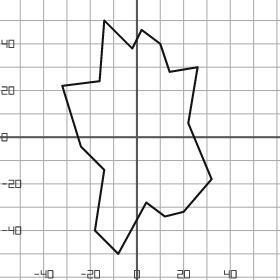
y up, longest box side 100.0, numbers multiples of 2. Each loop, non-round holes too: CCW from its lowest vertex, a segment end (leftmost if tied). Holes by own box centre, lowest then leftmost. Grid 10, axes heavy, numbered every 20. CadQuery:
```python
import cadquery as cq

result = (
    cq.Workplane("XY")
    .moveTo(-8.0, -50.0)
    .lineTo(4.0, -28.0)
    .lineTo(12.0, -34.0)
    .lineTo(20.0, -32.0)
    .lineTo(32.0, -18.0)
    .lineTo(22.0, 6.0)
    .lineTo(26.0, 30.0)
    .lineTo(14.0, 28.0)
    .lineTo(10.0, 40.0)
    .lineTo(2.0, 46.0)
    .lineTo(-2.0, 38.0)
    .lineTo(-14.0, 50.0)
    .lineTo(-16.0, 24.0)
    .lineTo(-32.0, 22.0)
    .lineTo(-24.0, -4.0)
    .lineTo(-14.0, -14.0)
    .lineTo(-18.0, -40.0)
    .close()
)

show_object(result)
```